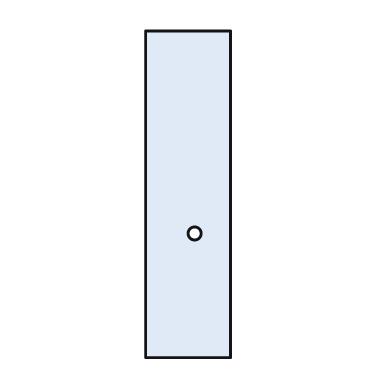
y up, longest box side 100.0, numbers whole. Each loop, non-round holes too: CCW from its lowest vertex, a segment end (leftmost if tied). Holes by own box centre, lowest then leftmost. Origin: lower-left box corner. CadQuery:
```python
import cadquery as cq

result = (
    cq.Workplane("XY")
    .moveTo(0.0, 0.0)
    .lineTo(26.0, 0.0)
    .lineTo(26.0, 100.0)
    .lineTo(0.0, 100.0)
    .close()
    .moveTo(15.0, 38.0)
    .circle(2.0)
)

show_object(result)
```